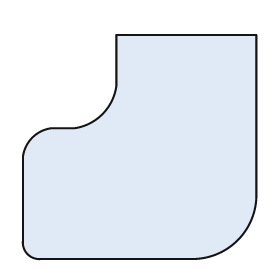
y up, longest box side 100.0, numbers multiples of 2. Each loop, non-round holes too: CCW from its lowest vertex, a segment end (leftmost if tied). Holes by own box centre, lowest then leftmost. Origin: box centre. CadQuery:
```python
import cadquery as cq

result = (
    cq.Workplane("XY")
    .moveTo(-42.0, -48.0)
    .lineTo(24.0, -48.0)
    .threePointArc((42.0, -40.0), (50.0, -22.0))
    .lineTo(50.0, 48.0)
    .lineTo(-10.0, 48.0)
    .lineTo(-10.0, 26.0)
    .threePointArc((-16.0, 14.0), (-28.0, 8.0))
    .lineTo(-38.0, 8.0)
    .threePointArc((-46.0, 4.0), (-50.0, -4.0))
    .lineTo(-50.0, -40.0)
    .threePointArc((-48.0, -46.0), (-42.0, -48.0))
    .close()
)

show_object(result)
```